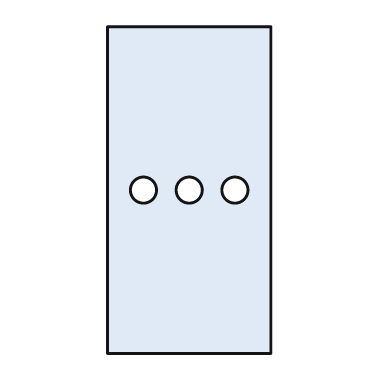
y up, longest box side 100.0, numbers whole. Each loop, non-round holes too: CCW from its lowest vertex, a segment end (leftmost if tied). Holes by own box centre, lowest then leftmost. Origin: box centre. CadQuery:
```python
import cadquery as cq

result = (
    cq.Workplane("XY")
    .moveTo(-25.0, -50.0)
    .lineTo(25.0, -50.0)
    .lineTo(25.0, 50.0)
    .lineTo(-25.0, 50.0)
    .close()
    .moveTo(-14.0, 0.0)
    .circle(4.0)
    .moveTo(0.0, 0.0)
    .circle(4.0)
    .moveTo(14.0, 0.0)
    .circle(4.0)
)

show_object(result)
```